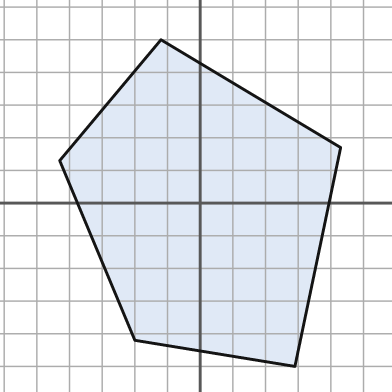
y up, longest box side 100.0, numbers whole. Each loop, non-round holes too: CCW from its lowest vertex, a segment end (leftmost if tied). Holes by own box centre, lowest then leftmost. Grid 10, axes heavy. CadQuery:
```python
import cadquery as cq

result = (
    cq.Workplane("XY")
    .moveTo(29.0, -50.0)
    .lineTo(43.0, 17.0)
    .lineTo(-12.0, 50.0)
    .lineTo(-43.0, 13.0)
    .lineTo(-20.0, -42.0)
    .close()
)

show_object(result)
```